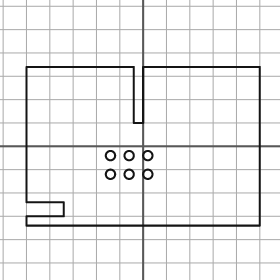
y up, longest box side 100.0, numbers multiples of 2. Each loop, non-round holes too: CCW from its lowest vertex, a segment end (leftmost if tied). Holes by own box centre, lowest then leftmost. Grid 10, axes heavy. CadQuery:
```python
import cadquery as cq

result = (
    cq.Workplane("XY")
    .moveTo(-50.0, -34.0)
    .lineTo(50.0, -34.0)
    .lineTo(50.0, 34.0)
    .lineTo(0.0, 34.0)
    .lineTo(0.0, 10.0)
    .lineTo(-4.0, 10.0)
    .lineTo(-4.0, 34.0)
    .lineTo(-50.0, 34.0)
    .lineTo(-50.0, -24.0)
    .lineTo(-34.0, -24.0)
    .lineTo(-34.0, -30.0)
    .lineTo(-50.0, -30.0)
    .close()
    .moveTo(-14.0, -12.0)
    .circle(2.0)
    .moveTo(-6.0, -12.0)
    .circle(2.0)
    .moveTo(2.0, -12.0)
    .circle(2.0)
    .moveTo(-14.0, -4.0)
    .circle(2.0)
    .moveTo(-6.0, -4.0)
    .circle(2.0)
    .moveTo(2.0, -4.0)
    .circle(2.0)
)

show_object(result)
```